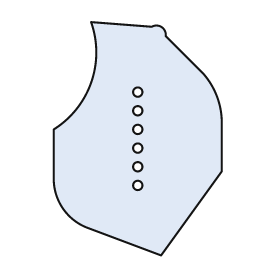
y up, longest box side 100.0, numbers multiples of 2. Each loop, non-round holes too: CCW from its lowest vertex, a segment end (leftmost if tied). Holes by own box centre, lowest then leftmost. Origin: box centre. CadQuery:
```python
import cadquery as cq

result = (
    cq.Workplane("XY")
    .moveTo(10.0, -50.0)
    .lineTo(36.0, -14.0)
    .lineTo(36.0, 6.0)
    .threePointArc((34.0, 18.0), (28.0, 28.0))
    .lineTo(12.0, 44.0)
    .threePointArc((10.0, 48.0), (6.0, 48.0))
    .lineTo(-20.0, 50.0)
    .threePointArc((-20.0, 24.0), (-36.0, 4.0))
    .lineTo(-36.0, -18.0)
    .threePointArc((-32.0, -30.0), (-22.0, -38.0))
    .close()
    .moveTo(0.0, -20.0)
    .circle(2.0)
    .moveTo(0.0, -12.0)
    .circle(2.0)
    .moveTo(0.0, -4.0)
    .circle(2.0)
    .moveTo(0.0, 4.0)
    .circle(2.0)
    .moveTo(0.0, 12.0)
    .circle(2.0)
    .moveTo(0.0, 20.0)
    .circle(2.0)
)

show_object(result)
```